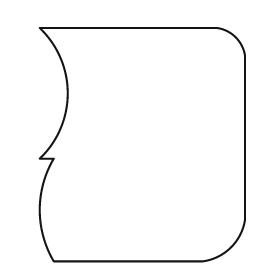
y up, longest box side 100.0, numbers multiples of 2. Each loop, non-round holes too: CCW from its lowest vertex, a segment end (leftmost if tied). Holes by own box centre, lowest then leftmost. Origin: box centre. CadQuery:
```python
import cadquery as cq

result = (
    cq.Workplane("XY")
    .moveTo(-38.0, -50.0)
    .lineTo(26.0, -50.0)
    .threePointArc((38.0, -44.0), (44.0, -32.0))
    .lineTo(44.0, 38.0)
    .threePointArc((40.0, 46.0), (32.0, 50.0))
    .lineTo(-44.0, 50.0)
    .threePointArc((-32.0, 22.0), (-44.0, -6.0))
    .lineTo(-38.0, -6.0)
    .threePointArc((-44.0, -28.0), (-38.0, -50.0))
    .close()
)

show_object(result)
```